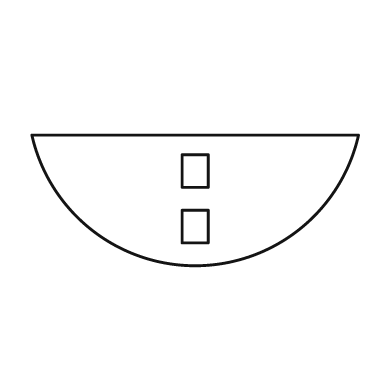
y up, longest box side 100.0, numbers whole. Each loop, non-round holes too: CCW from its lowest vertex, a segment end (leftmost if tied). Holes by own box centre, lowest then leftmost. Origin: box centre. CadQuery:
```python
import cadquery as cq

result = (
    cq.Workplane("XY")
    .moveTo(-50.0, 20.0)
    .threePointArc((0.0, -20.0), (50.0, 20.0))
    .close()
    .moveTo(-4.0, -13.0)
    .lineTo(4.0, -13.0)
    .lineTo(4.0, -3.0)
    .lineTo(-4.0, -3.0)
    .close()
    .moveTo(-4.0, 4.0)
    .lineTo(4.0, 4.0)
    .lineTo(4.0, 14.0)
    .lineTo(-4.0, 14.0)
    .close()
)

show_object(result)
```